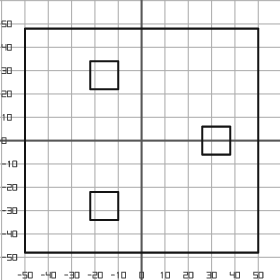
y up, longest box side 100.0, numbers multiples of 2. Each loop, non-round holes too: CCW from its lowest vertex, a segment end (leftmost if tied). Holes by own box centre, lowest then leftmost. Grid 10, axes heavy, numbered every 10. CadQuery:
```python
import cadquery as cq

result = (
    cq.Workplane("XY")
    .moveTo(-50.0, -48.0)
    .lineTo(50.0, -48.0)
    .lineTo(50.0, 48.0)
    .lineTo(-50.0, 48.0)
    .close()
    .moveTo(-22.0, -34.0)
    .lineTo(-10.0, -34.0)
    .lineTo(-10.0, -22.0)
    .lineTo(-22.0, -22.0)
    .close()
    .moveTo(26.0, -6.0)
    .lineTo(38.0, -6.0)
    .lineTo(38.0, 6.0)
    .lineTo(26.0, 6.0)
    .close()
    .moveTo(-22.0, 22.0)
    .lineTo(-10.0, 22.0)
    .lineTo(-10.0, 34.0)
    .lineTo(-22.0, 34.0)
    .close()
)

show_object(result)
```